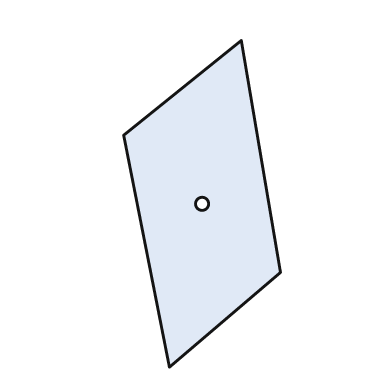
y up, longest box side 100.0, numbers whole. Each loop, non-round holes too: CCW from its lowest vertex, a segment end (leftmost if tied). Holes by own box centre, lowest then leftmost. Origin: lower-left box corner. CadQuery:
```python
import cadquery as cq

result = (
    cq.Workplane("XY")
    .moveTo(14.0, 0.0)
    .lineTo(48.0, 29.0)
    .lineTo(36.0, 100.0)
    .lineTo(0.0, 71.0)
    .close()
    .moveTo(24.0, 50.0)
    .circle(2.0)
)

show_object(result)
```